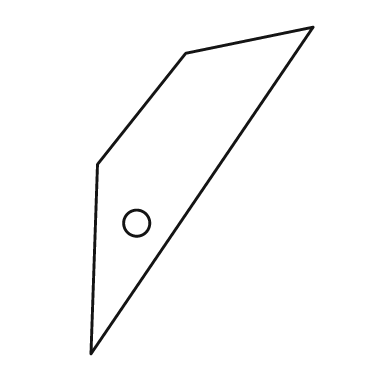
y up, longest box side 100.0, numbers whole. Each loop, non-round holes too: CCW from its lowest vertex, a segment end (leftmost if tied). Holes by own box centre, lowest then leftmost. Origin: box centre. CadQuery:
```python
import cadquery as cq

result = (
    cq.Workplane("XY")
    .moveTo(-34.0, -50.0)
    .lineTo(34.0, 50.0)
    .lineTo(-5.0, 42.0)
    .lineTo(-32.0, 8.0)
    .close()
    .moveTo(-20.0, -10.0)
    .circle(4.0)
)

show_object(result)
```